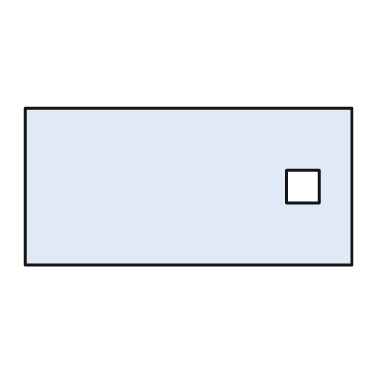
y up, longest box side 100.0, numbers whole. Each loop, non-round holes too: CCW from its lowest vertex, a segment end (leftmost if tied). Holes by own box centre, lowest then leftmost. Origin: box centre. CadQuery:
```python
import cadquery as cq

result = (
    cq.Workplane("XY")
    .moveTo(-50.0, -24.0)
    .lineTo(50.0, -24.0)
    .lineTo(50.0, 24.0)
    .lineTo(-50.0, 24.0)
    .close()
    .moveTo(30.0, -5.0)
    .lineTo(40.0, -5.0)
    .lineTo(40.0, 5.0)
    .lineTo(30.0, 5.0)
    .close()
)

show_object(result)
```